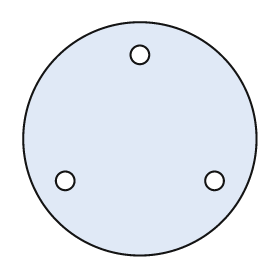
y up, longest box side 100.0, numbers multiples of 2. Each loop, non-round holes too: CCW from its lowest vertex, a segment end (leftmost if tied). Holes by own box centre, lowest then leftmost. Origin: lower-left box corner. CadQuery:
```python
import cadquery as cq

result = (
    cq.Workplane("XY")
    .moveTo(50.0, 50.0)
    .circle(50.0)
    .moveTo(18.0, 32.0)
    .circle(4.0)
    .moveTo(82.0, 32.0)
    .circle(4.0)
    .moveTo(50.0, 86.0)
    .circle(4.0)
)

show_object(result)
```